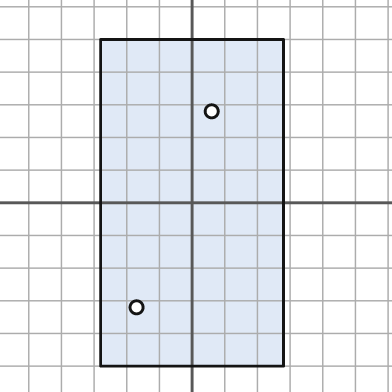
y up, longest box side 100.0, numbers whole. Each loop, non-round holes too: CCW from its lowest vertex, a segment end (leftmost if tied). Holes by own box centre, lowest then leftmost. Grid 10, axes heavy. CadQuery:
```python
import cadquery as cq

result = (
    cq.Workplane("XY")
    .moveTo(-28.0, -50.0)
    .lineTo(28.0, -50.0)
    .lineTo(28.0, 50.0)
    .lineTo(-28.0, 50.0)
    .close()
    .moveTo(-17.0, -32.0)
    .circle(2.0)
    .moveTo(6.0, 28.0)
    .circle(2.0)
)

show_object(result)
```